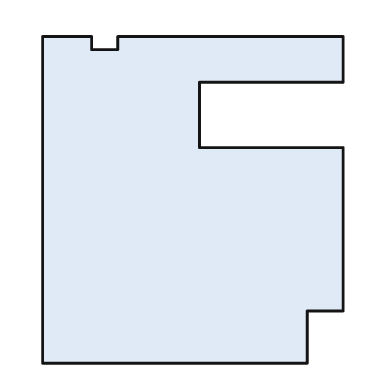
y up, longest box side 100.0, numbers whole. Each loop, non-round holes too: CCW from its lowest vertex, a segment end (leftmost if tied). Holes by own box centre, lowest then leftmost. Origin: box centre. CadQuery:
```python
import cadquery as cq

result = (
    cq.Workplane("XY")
    .moveTo(-46.0, -50.0)
    .lineTo(35.0, -50.0)
    .lineTo(35.0, -34.0)
    .lineTo(46.0, -34.0)
    .lineTo(46.0, 16.0)
    .lineTo(2.0, 16.0)
    .lineTo(2.0, 36.0)
    .lineTo(46.0, 36.0)
    .lineTo(46.0, 50.0)
    .lineTo(-23.0, 50.0)
    .lineTo(-23.0, 46.0)
    .lineTo(-31.0, 46.0)
    .lineTo(-31.0, 50.0)
    .lineTo(-46.0, 50.0)
    .close()
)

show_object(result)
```